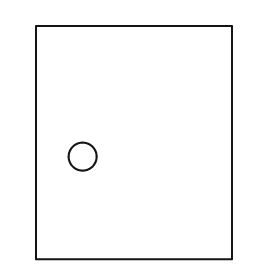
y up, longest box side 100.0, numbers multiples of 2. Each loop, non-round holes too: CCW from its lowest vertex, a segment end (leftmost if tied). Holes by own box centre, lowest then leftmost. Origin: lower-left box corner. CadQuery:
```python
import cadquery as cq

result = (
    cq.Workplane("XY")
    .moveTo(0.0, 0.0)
    .lineTo(84.0, 0.0)
    .lineTo(84.0, 100.0)
    .lineTo(0.0, 100.0)
    .close()
    .moveTo(20.0, 44.0)
    .circle(6.0)
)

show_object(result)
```